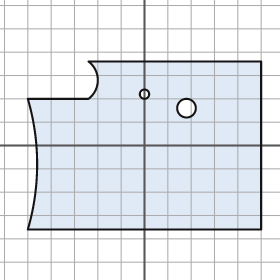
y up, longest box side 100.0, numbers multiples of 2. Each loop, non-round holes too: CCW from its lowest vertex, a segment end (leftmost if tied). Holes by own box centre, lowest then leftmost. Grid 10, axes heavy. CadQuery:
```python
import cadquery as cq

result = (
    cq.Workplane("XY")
    .moveTo(-50.0, -36.0)
    .lineTo(50.0, -36.0)
    .lineTo(50.0, 36.0)
    .lineTo(-24.0, 36.0)
    .threePointArc((-20.0, 28.0), (-24.0, 20.0))
    .lineTo(-50.0, 20.0)
    .threePointArc((-46.0, -8.0), (-50.0, -36.0))
    .close()
    .moveTo(18.0, 16.0)
    .circle(4.0)
    .moveTo(0.0, 22.0)
    .circle(2.0)
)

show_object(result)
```